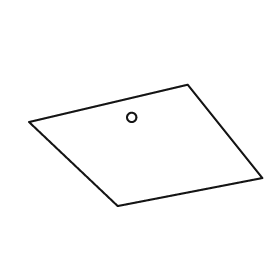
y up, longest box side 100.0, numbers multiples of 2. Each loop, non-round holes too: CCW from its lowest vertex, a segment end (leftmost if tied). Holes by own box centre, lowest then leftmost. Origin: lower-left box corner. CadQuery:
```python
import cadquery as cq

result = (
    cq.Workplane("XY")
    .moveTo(38.0, 0.0)
    .lineTo(100.0, 12.0)
    .lineTo(68.0, 52.0)
    .lineTo(0.0, 36.0)
    .close()
    .moveTo(44.0, 38.0)
    .circle(2.0)
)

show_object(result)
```